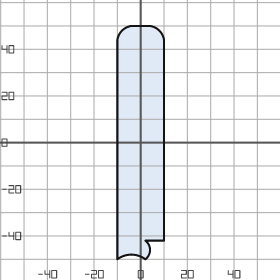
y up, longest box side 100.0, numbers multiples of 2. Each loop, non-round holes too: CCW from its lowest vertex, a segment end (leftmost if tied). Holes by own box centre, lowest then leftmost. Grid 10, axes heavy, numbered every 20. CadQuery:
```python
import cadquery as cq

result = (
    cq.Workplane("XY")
    .moveTo(-10.0, -50.0)
    .threePointArc((-4.0, -48.0), (2.0, -50.0))
    .threePointArc((4.0, -46.0), (2.0, -42.0))
    .lineTo(10.0, -42.0)
    .lineTo(10.0, 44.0)
    .threePointArc((8.0, 48.0), (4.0, 50.0))
    .lineTo(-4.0, 50.0)
    .threePointArc((-8.0, 48.0), (-10.0, 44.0))
    .close()
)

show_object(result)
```